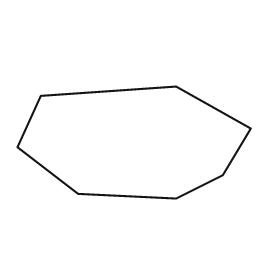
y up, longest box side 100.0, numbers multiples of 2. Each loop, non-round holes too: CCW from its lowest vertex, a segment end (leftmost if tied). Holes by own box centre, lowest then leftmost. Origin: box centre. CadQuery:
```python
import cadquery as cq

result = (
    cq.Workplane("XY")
    .moveTo(18.0, -24.0)
    .lineTo(38.0, -14.0)
    .lineTo(50.0, 6.0)
    .lineTo(18.0, 24.0)
    .lineTo(-40.0, 20.0)
    .lineTo(-50.0, -2.0)
    .lineTo(-24.0, -22.0)
    .close()
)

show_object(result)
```